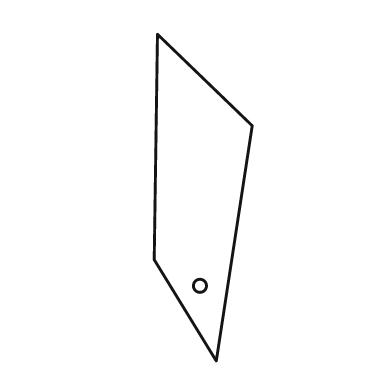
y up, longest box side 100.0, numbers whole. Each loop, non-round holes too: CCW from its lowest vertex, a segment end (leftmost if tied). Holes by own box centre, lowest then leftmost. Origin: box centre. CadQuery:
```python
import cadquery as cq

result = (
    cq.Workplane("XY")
    .moveTo(4.0, -50.0)
    .lineTo(15.0, 22.0)
    .lineTo(-14.0, 50.0)
    .lineTo(-15.0, -19.0)
    .close()
    .moveTo(-1.0, -27.0)
    .circle(2.0)
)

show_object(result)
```